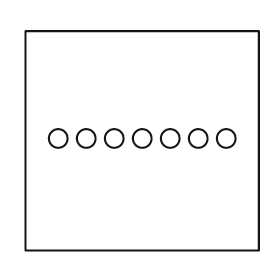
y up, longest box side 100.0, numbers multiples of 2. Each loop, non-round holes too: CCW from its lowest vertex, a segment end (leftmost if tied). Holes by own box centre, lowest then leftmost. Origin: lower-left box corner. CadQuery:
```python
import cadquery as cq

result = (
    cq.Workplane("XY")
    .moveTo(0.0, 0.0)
    .lineTo(100.0, 0.0)
    .lineTo(100.0, 94.0)
    .lineTo(0.0, 94.0)
    .close()
    .moveTo(14.0, 48.0)
    .circle(4.0)
    .moveTo(26.0, 48.0)
    .circle(4.0)
    .moveTo(38.0, 48.0)
    .circle(4.0)
    .moveTo(50.0, 48.0)
    .circle(4.0)
    .moveTo(62.0, 48.0)
    .circle(4.0)
    .moveTo(74.0, 48.0)
    .circle(4.0)
    .moveTo(86.0, 48.0)
    .circle(4.0)
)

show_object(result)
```